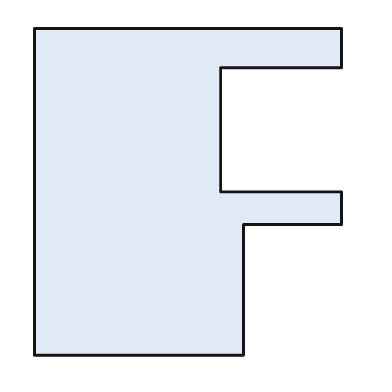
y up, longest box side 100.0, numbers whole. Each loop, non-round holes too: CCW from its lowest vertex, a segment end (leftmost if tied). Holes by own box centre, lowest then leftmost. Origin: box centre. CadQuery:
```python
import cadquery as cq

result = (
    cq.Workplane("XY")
    .moveTo(-47.0, -50.0)
    .lineTo(17.0, -50.0)
    .lineTo(17.0, -10.0)
    .lineTo(47.0, -10.0)
    .lineTo(47.0, 0.0)
    .lineTo(10.0, 0.0)
    .lineTo(10.0, 38.0)
    .lineTo(47.0, 38.0)
    .lineTo(47.0, 50.0)
    .lineTo(-47.0, 50.0)
    .close()
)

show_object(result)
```